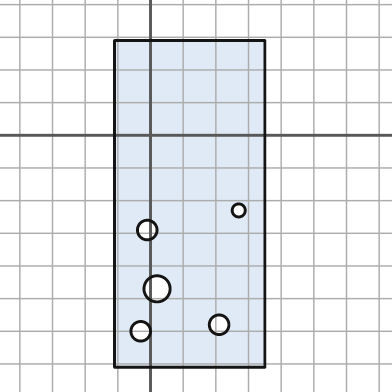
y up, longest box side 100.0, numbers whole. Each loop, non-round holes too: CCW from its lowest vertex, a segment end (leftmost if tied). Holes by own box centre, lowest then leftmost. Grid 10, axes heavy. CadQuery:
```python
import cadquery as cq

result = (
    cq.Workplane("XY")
    .moveTo(-11.0, -71.0)
    .lineTo(35.0, -71.0)
    .lineTo(35.0, 29.0)
    .lineTo(-11.0, 29.0)
    .close()
    .moveTo(-3.0, -60.0)
    .circle(3.0)
    .moveTo(21.0, -58.0)
    .circle(3.0)
    .moveTo(2.0, -47.0)
    .circle(4.0)
    .moveTo(-1.0, -29.0)
    .circle(3.0)
    .moveTo(27.0, -23.0)
    .circle(2.0)
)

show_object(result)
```